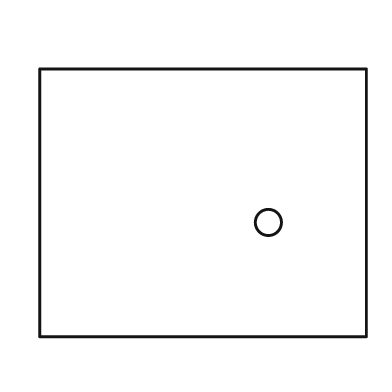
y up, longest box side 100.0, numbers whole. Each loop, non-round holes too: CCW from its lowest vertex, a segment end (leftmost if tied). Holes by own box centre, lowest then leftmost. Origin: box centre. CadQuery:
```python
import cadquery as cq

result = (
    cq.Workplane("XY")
    .moveTo(-50.0, -41.0)
    .lineTo(50.0, -41.0)
    .lineTo(50.0, 41.0)
    .lineTo(-50.0, 41.0)
    .close()
    .moveTo(20.0, -6.0)
    .circle(4.0)
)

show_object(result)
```